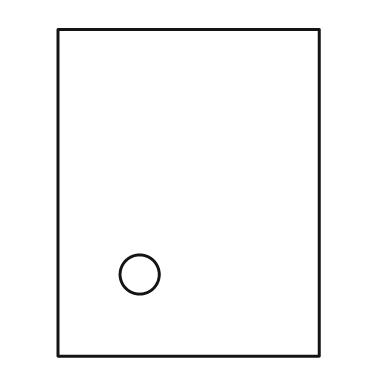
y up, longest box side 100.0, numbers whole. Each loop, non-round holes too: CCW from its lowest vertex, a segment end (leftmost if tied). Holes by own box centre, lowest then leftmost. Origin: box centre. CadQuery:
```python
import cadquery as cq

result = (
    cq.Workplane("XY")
    .moveTo(-40.0, -50.0)
    .lineTo(40.0, -50.0)
    .lineTo(40.0, 50.0)
    .lineTo(-40.0, 50.0)
    .close()
    .moveTo(-15.0, -25.0)
    .circle(6.0)
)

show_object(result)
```